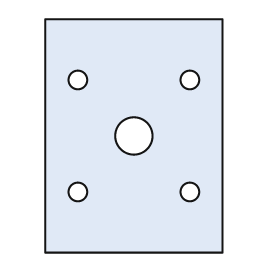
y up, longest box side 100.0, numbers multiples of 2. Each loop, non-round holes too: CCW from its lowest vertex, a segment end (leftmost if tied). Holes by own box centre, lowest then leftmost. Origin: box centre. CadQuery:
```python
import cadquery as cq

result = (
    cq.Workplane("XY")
    .moveTo(-38.0, -50.0)
    .lineTo(38.0, -50.0)
    .lineTo(38.0, 50.0)
    .lineTo(-38.0, 50.0)
    .close()
    .moveTo(-24.0, -24.0)
    .circle(4.0)
    .moveTo(24.0, -24.0)
    .circle(4.0)
    .moveTo(0.0, 0.0)
    .circle(8.0)
    .moveTo(-24.0, 24.0)
    .circle(4.0)
    .moveTo(24.0, 24.0)
    .circle(4.0)
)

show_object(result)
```